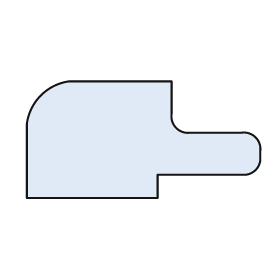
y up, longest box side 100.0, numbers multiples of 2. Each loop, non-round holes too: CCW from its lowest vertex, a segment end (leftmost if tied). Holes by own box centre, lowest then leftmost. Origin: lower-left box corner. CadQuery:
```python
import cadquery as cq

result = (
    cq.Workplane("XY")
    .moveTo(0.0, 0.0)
    .lineTo(56.0, 0.0)
    .lineTo(56.0, 10.0)
    .lineTo(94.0, 10.0)
    .threePointArc((98.0, 12.0), (100.0, 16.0))
    .lineTo(100.0, 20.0)
    .threePointArc((98.0, 26.0), (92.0, 28.0))
    .lineTo(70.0, 28.0)
    .threePointArc((64.0, 30.0), (62.0, 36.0))
    .lineTo(62.0, 50.0)
    .lineTo(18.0, 50.0)
    .threePointArc((6.0, 44.0), (0.0, 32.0))
    .close()
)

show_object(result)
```